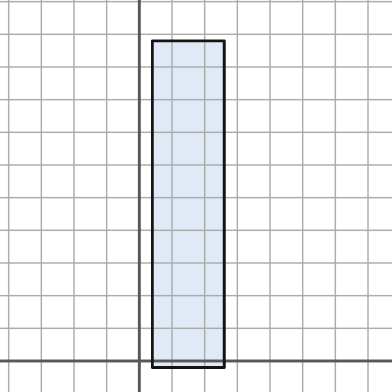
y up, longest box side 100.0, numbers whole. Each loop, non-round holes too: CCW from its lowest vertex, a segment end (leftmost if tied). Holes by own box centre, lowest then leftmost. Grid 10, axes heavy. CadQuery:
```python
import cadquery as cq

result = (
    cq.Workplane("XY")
    .moveTo(4.0, -2.0)
    .lineTo(26.0, -2.0)
    .lineTo(26.0, 98.0)
    .lineTo(4.0, 98.0)
    .close()
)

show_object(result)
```